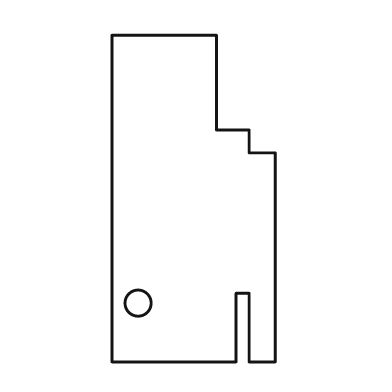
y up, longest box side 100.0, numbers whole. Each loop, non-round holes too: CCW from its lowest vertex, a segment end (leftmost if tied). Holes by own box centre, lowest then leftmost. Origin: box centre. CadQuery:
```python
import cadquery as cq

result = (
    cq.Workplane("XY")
    .moveTo(-25.0, -50.0)
    .lineTo(13.0, -50.0)
    .lineTo(13.0, -29.0)
    .lineTo(17.0, -29.0)
    .lineTo(17.0, -50.0)
    .lineTo(25.0, -50.0)
    .lineTo(25.0, 14.0)
    .lineTo(17.0, 14.0)
    .lineTo(17.0, 21.0)
    .lineTo(7.0, 21.0)
    .lineTo(7.0, 50.0)
    .lineTo(-25.0, 50.0)
    .close()
    .moveTo(-17.0, -32.0)
    .circle(4.0)
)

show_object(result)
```